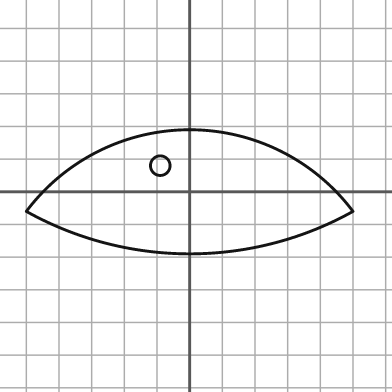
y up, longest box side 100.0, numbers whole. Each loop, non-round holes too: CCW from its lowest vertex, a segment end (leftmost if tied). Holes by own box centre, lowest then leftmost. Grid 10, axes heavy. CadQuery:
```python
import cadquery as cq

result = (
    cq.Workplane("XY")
    .moveTo(-50.0, -6.0)
    .threePointArc((0.0, -19.0), (50.0, -6.0))
    .threePointArc((0.0, 19.0), (-50.0, -6.0))
    .close()
    .moveTo(-9.0, 8.0)
    .circle(3.0)
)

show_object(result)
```